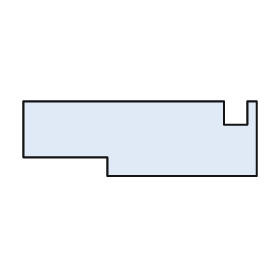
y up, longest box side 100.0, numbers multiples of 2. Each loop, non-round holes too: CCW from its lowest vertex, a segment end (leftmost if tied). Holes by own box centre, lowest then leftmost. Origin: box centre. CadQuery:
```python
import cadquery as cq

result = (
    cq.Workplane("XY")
    .moveTo(-14.0, -16.0)
    .lineTo(50.0, -16.0)
    .lineTo(50.0, 16.0)
    .lineTo(46.0, 16.0)
    .lineTo(46.0, 6.0)
    .lineTo(36.0, 6.0)
    .lineTo(36.0, 16.0)
    .lineTo(-50.0, 16.0)
    .lineTo(-50.0, -8.0)
    .lineTo(-14.0, -8.0)
    .close()
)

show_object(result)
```